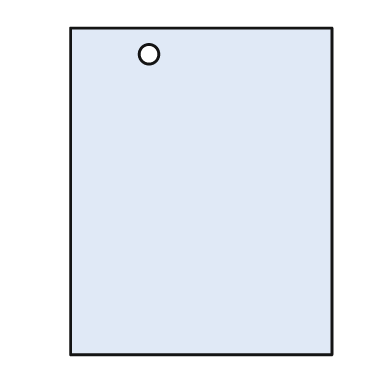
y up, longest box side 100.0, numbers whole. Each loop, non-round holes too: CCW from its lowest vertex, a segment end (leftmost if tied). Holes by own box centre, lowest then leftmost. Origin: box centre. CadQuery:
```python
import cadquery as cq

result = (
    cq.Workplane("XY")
    .moveTo(-40.0, -50.0)
    .lineTo(40.0, -50.0)
    .lineTo(40.0, 50.0)
    .lineTo(-40.0, 50.0)
    .close()
    .moveTo(-16.0, 42.0)
    .circle(3.0)
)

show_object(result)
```